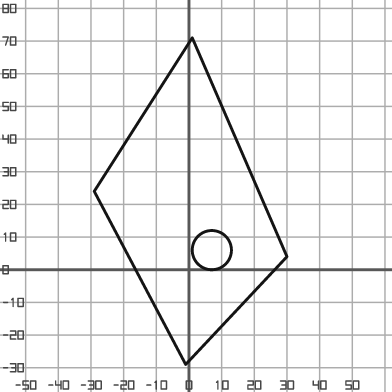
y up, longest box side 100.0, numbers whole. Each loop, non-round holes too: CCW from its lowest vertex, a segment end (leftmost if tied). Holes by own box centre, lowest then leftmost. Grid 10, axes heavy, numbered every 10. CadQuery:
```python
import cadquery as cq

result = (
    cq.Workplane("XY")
    .moveTo(-1.0, -29.0)
    .lineTo(30.0, 4.0)
    .lineTo(1.0, 71.0)
    .lineTo(-29.0, 24.0)
    .close()
    .moveTo(7.0, 6.0)
    .circle(6.0)
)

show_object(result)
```